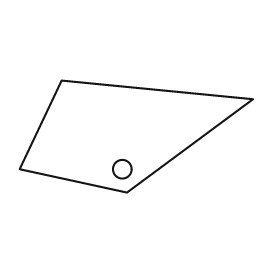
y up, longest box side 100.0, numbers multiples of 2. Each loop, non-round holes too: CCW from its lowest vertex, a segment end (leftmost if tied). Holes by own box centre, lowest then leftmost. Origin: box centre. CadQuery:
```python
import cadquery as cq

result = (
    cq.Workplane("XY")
    .moveTo(-4.0, -24.0)
    .lineTo(50.0, 16.0)
    .lineTo(-32.0, 24.0)
    .lineTo(-50.0, -14.0)
    .close()
    .moveTo(-6.0, -14.0)
    .circle(4.0)
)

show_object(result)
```